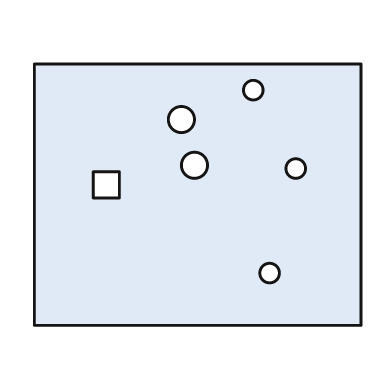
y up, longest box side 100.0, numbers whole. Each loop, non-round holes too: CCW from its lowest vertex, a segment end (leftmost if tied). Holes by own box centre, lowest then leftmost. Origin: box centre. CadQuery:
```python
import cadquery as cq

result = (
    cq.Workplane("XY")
    .moveTo(-50.0, -40.0)
    .lineTo(50.0, -40.0)
    .lineTo(50.0, 40.0)
    .lineTo(-50.0, 40.0)
    .close()
    .moveTo(22.0, -24.0)
    .circle(3.0)
    .moveTo(-32.0, -1.0)
    .lineTo(-24.0, -1.0)
    .lineTo(-24.0, 7.0)
    .lineTo(-32.0, 7.0)
    .close()
    .moveTo(30.0, 8.0)
    .circle(3.0)
    .moveTo(-1.0, 9.0)
    .circle(4.0)
    .moveTo(-5.0, 23.0)
    .circle(4.0)
    .moveTo(17.0, 32.0)
    .circle(3.0)
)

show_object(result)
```